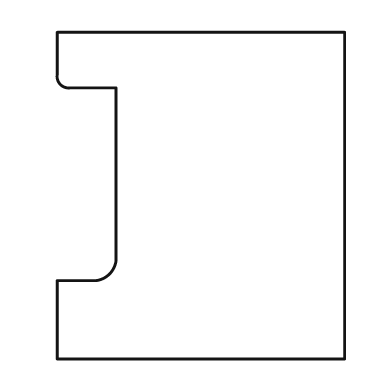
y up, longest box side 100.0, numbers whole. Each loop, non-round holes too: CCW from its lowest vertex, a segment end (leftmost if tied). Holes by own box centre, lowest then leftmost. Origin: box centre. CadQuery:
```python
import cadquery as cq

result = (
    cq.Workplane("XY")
    .moveTo(-44.0, -50.0)
    .lineTo(44.0, -50.0)
    .lineTo(44.0, 50.0)
    .lineTo(-44.0, 50.0)
    .lineTo(-44.0, 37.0)
    .threePointArc((-43.0, 34.0), (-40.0, 33.0))
    .lineTo(-26.0, 33.0)
    .lineTo(-26.0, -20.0)
    .threePointArc((-28.0, -24.0), (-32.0, -26.0))
    .lineTo(-44.0, -26.0)
    .close()
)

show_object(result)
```